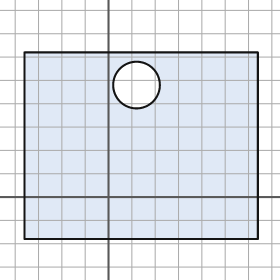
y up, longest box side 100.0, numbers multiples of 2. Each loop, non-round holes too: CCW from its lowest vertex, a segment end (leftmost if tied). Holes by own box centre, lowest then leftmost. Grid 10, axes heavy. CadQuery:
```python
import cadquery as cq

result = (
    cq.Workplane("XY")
    .moveTo(-36.0, -18.0)
    .lineTo(64.0, -18.0)
    .lineTo(64.0, 62.0)
    .lineTo(-36.0, 62.0)
    .close()
    .moveTo(12.0, 48.0)
    .circle(10.0)
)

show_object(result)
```